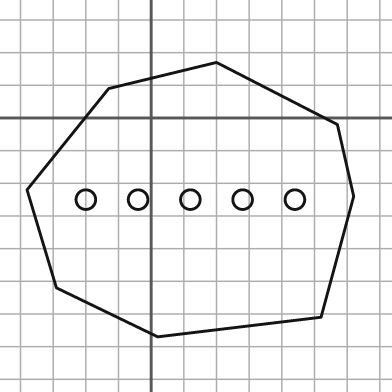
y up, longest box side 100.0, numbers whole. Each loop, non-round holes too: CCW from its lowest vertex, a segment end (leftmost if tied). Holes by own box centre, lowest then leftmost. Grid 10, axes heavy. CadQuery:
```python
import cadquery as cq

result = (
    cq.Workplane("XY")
    .moveTo(2.0, -67.0)
    .lineTo(52.0, -61.0)
    .lineTo(62.0, -24.0)
    .lineTo(57.0, -2.0)
    .lineTo(20.0, 17.0)
    .lineTo(-13.0, 9.0)
    .lineTo(-38.0, -22.0)
    .lineTo(-29.0, -52.0)
    .close()
    .moveTo(-20.0, -25.0)
    .circle(3.0)
    .moveTo(-4.0, -25.0)
    .circle(3.0)
    .moveTo(12.0, -25.0)
    .circle(3.0)
    .moveTo(28.0, -25.0)
    .circle(3.0)
    .moveTo(44.0, -25.0)
    .circle(3.0)
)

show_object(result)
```